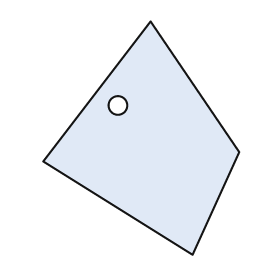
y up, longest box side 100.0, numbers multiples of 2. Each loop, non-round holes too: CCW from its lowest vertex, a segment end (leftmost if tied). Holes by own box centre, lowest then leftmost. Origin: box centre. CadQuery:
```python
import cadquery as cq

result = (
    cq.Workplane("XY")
    .moveTo(22.0, -50.0)
    .lineTo(42.0, -6.0)
    .lineTo(4.0, 50.0)
    .lineTo(-42.0, -10.0)
    .close()
    .moveTo(-10.0, 14.0)
    .circle(4.0)
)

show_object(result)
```